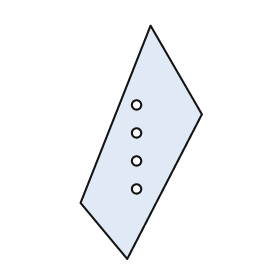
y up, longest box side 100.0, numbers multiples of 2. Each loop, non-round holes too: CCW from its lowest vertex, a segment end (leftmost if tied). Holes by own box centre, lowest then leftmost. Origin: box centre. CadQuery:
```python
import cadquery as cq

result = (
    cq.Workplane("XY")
    .moveTo(-6.0, -50.0)
    .lineTo(26.0, 12.0)
    .lineTo(4.0, 50.0)
    .lineTo(-26.0, -26.0)
    .close()
    .moveTo(-2.0, -20.0)
    .circle(2.0)
    .moveTo(-2.0, -8.0)
    .circle(2.0)
    .moveTo(-2.0, 4.0)
    .circle(2.0)
    .moveTo(-2.0, 16.0)
    .circle(2.0)
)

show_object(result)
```